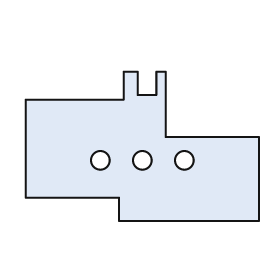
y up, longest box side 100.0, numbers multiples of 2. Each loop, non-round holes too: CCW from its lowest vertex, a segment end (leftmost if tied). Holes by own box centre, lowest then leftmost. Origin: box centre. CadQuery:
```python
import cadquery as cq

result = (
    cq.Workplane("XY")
    .moveTo(-10.0, -32.0)
    .lineTo(50.0, -32.0)
    .lineTo(50.0, 4.0)
    .lineTo(10.0, 4.0)
    .lineTo(10.0, 32.0)
    .lineTo(6.0, 32.0)
    .lineTo(6.0, 22.0)
    .lineTo(-2.0, 22.0)
    .lineTo(-2.0, 32.0)
    .lineTo(-8.0, 32.0)
    .lineTo(-8.0, 20.0)
    .lineTo(-50.0, 20.0)
    .lineTo(-50.0, -22.0)
    .lineTo(-10.0, -22.0)
    .close()
    .moveTo(-18.0, -6.0)
    .circle(4.0)
    .moveTo(0.0, -6.0)
    .circle(4.0)
    .moveTo(18.0, -6.0)
    .circle(4.0)
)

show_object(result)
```